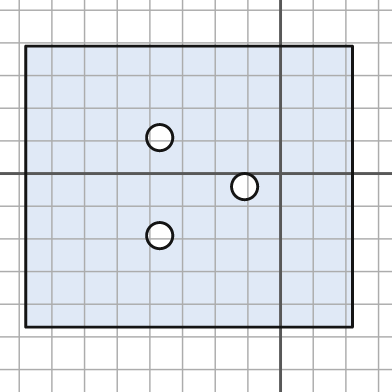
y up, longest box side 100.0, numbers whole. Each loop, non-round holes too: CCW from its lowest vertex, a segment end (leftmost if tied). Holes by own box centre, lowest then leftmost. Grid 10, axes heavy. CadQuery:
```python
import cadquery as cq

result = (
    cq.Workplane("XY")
    .moveTo(-78.0, -47.0)
    .lineTo(22.0, -47.0)
    .lineTo(22.0, 39.0)
    .lineTo(-78.0, 39.0)
    .close()
    .moveTo(-37.0, -19.0)
    .circle(4.0)
    .moveTo(-11.0, -4.0)
    .circle(4.0)
    .moveTo(-37.0, 11.0)
    .circle(4.0)
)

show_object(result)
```